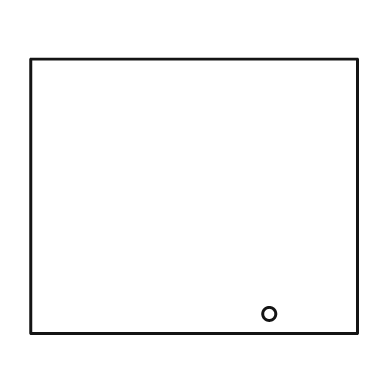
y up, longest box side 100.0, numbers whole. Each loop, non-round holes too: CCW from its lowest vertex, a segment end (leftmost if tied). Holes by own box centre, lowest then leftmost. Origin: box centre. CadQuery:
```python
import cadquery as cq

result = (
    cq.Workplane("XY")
    .moveTo(-50.0, -42.0)
    .lineTo(50.0, -42.0)
    .lineTo(50.0, 42.0)
    .lineTo(-50.0, 42.0)
    .close()
    .moveTo(23.0, -36.0)
    .circle(2.0)
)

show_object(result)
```